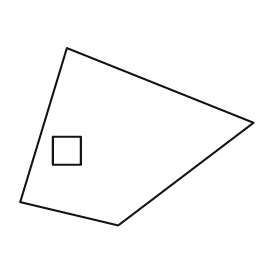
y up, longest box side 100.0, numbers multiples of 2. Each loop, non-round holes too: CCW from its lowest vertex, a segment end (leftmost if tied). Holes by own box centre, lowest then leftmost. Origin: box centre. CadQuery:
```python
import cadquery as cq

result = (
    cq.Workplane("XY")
    .moveTo(-8.0, -38.0)
    .lineTo(50.0, 6.0)
    .lineTo(-30.0, 38.0)
    .lineTo(-50.0, -28.0)
    .close()
    .moveTo(-36.0, -12.0)
    .lineTo(-24.0, -12.0)
    .lineTo(-24.0, 0.0)
    .lineTo(-36.0, 0.0)
    .close()
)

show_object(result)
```